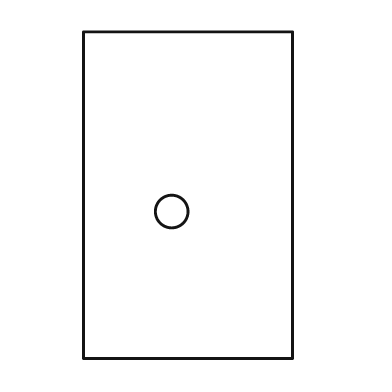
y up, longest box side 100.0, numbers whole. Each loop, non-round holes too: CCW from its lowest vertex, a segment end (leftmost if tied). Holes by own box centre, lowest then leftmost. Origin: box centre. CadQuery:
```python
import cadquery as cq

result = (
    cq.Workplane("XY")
    .moveTo(-32.0, -50.0)
    .lineTo(32.0, -50.0)
    .lineTo(32.0, 50.0)
    .lineTo(-32.0, 50.0)
    .close()
    .moveTo(-5.0, -5.0)
    .circle(5.0)
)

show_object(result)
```